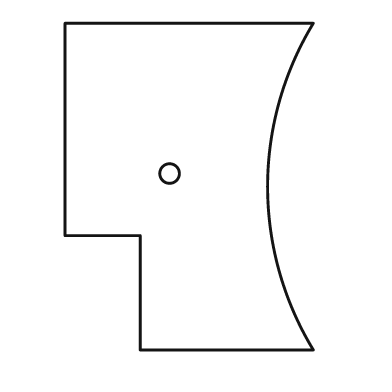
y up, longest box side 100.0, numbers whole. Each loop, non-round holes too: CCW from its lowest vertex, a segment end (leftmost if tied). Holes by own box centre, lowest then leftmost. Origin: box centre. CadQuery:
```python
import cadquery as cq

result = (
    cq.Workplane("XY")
    .moveTo(-15.0, -50.0)
    .lineTo(38.0, -50.0)
    .threePointArc((24.0, 0.0), (38.0, 50.0))
    .lineTo(-38.0, 50.0)
    .lineTo(-38.0, -15.0)
    .lineTo(-15.0, -15.0)
    .close()
    .moveTo(-6.0, 4.0)
    .circle(3.0)
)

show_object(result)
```